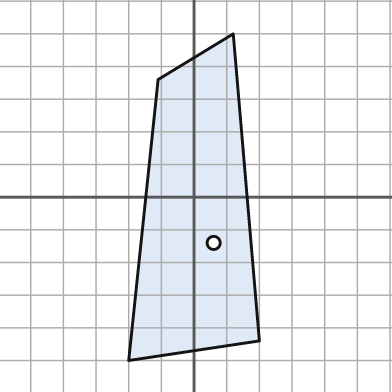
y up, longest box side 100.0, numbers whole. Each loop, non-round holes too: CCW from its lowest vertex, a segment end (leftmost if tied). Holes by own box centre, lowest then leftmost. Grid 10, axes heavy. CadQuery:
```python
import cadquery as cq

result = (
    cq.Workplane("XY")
    .moveTo(-20.0, -50.0)
    .lineTo(20.0, -44.0)
    .lineTo(12.0, 50.0)
    .lineTo(-11.0, 36.0)
    .close()
    .moveTo(6.0, -14.0)
    .circle(2.0)
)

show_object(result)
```